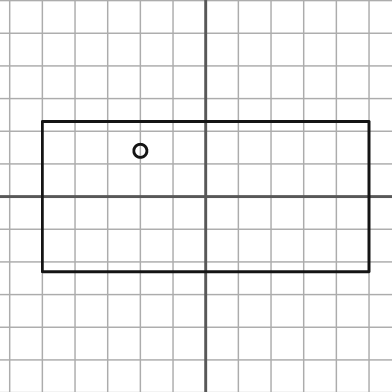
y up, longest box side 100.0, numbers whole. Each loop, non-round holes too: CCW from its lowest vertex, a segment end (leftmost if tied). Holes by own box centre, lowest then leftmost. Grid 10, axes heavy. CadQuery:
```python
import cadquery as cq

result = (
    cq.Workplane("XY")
    .moveTo(-50.0, -23.0)
    .lineTo(50.0, -23.0)
    .lineTo(50.0, 23.0)
    .lineTo(-50.0, 23.0)
    .close()
    .moveTo(-20.0, 14.0)
    .circle(2.0)
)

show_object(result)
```